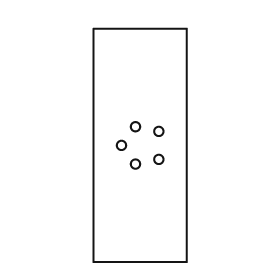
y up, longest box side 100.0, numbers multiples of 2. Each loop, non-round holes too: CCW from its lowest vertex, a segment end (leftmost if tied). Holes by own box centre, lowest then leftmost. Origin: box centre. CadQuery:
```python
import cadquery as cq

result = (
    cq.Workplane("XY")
    .moveTo(-20.0, -50.0)
    .lineTo(20.0, -50.0)
    .lineTo(20.0, 50.0)
    .lineTo(-20.0, 50.0)
    .close()
    .moveTo(-2.0, -8.0)
    .circle(2.0)
    .moveTo(8.0, -6.0)
    .circle(2.0)
    .moveTo(-8.0, 0.0)
    .circle(2.0)
    .moveTo(8.0, 6.0)
    .circle(2.0)
    .moveTo(-2.0, 8.0)
    .circle(2.0)
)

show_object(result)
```